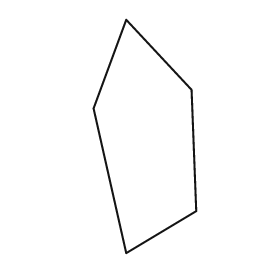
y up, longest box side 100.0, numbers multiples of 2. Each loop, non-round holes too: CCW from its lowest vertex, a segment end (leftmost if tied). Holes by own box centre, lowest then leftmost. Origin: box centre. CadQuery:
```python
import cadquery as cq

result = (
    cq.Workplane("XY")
    .moveTo(-8.0, -50.0)
    .lineTo(22.0, -32.0)
    .lineTo(20.0, 20.0)
    .lineTo(-8.0, 50.0)
    .lineTo(-22.0, 12.0)
    .close()
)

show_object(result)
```